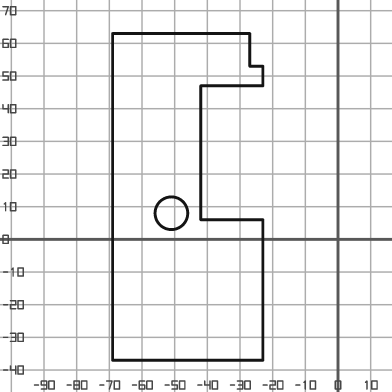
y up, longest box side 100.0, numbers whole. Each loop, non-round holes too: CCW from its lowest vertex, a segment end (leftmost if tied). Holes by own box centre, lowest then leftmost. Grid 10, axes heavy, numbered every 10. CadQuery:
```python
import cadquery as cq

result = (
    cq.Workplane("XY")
    .moveTo(-69.0, -37.0)
    .lineTo(-23.0, -37.0)
    .lineTo(-23.0, 6.0)
    .lineTo(-42.0, 6.0)
    .lineTo(-42.0, 47.0)
    .lineTo(-23.0, 47.0)
    .lineTo(-23.0, 53.0)
    .lineTo(-27.0, 53.0)
    .lineTo(-27.0, 63.0)
    .lineTo(-69.0, 63.0)
    .close()
    .moveTo(-51.0, 8.0)
    .circle(5.0)
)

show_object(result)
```